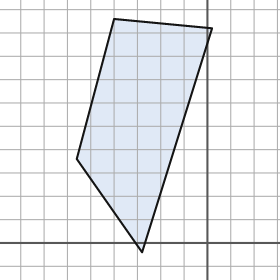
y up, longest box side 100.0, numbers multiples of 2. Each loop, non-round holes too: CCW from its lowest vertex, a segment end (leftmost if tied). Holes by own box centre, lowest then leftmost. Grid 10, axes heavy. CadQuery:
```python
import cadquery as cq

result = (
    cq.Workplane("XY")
    .moveTo(-28.0, -4.0)
    .lineTo(2.0, 92.0)
    .lineTo(-40.0, 96.0)
    .lineTo(-56.0, 36.0)
    .close()
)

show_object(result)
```